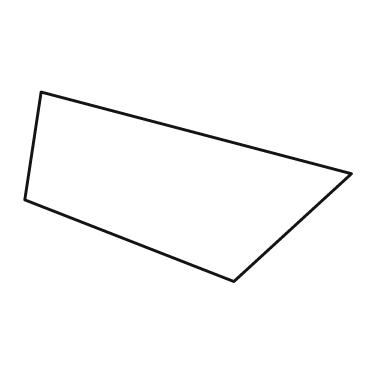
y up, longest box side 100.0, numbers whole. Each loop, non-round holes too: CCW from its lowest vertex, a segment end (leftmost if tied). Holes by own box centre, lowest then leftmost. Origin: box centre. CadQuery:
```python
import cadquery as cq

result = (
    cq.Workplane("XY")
    .moveTo(14.0, -29.0)
    .lineTo(50.0, 4.0)
    .lineTo(-45.0, 29.0)
    .lineTo(-50.0, -4.0)
    .close()
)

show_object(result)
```